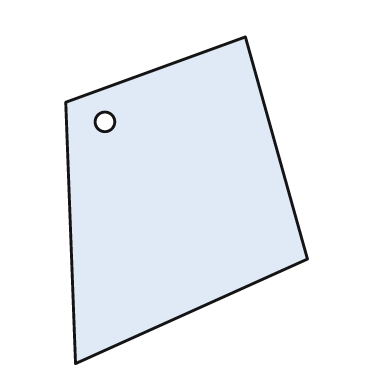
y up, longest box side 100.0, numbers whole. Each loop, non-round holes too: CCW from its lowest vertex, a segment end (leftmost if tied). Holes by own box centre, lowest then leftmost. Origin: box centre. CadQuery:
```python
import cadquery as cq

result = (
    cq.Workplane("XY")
    .moveTo(-34.0, -50.0)
    .lineTo(37.0, -18.0)
    .lineTo(18.0, 50.0)
    .lineTo(-37.0, 30.0)
    .close()
    .moveTo(-25.0, 24.0)
    .circle(3.0)
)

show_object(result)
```